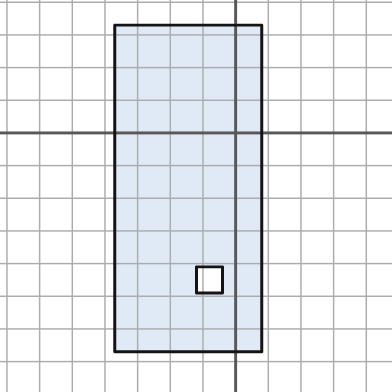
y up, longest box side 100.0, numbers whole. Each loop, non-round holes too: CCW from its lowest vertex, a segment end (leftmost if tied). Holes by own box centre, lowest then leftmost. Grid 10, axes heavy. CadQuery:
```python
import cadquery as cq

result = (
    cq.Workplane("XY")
    .moveTo(-37.0, -67.0)
    .lineTo(8.0, -67.0)
    .lineTo(8.0, 33.0)
    .lineTo(-37.0, 33.0)
    .close()
    .moveTo(-12.0, -49.0)
    .lineTo(-4.0, -49.0)
    .lineTo(-4.0, -41.0)
    .lineTo(-12.0, -41.0)
    .close()
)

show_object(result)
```